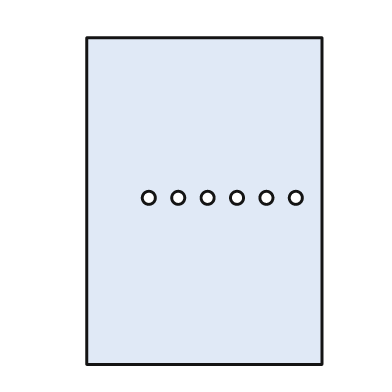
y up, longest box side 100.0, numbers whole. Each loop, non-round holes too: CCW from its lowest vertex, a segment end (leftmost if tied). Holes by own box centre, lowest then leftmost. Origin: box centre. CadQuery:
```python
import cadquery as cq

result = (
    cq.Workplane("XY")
    .moveTo(-36.0, -50.0)
    .lineTo(36.0, -50.0)
    .lineTo(36.0, 50.0)
    .lineTo(-36.0, 50.0)
    .close()
    .moveTo(-17.0, 1.0)
    .circle(2.0)
    .moveTo(-8.0, 1.0)
    .circle(2.0)
    .moveTo(1.0, 1.0)
    .circle(2.0)
    .moveTo(10.0, 1.0)
    .circle(2.0)
    .moveTo(19.0, 1.0)
    .circle(2.0)
    .moveTo(28.0, 1.0)
    .circle(2.0)
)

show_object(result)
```